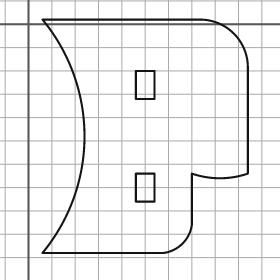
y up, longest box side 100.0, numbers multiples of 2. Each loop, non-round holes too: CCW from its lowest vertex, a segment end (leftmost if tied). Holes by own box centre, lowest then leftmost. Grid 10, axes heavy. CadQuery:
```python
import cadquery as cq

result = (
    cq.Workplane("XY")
    .moveTo(6.0, -98.0)
    .lineTo(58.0, -98.0)
    .threePointArc((66.0, -94.0), (70.0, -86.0))
    .lineTo(70.0, -64.0)
    .threePointArc((82.0, -66.0), (94.0, -64.0))
    .lineTo(94.0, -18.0)
    .threePointArc((88.0, -4.0), (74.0, 2.0))
    .lineTo(6.0, 2.0)
    .threePointArc((24.0, -48.0), (6.0, -98.0))
    .close()
    .moveTo(46.0, -76.0)
    .lineTo(54.0, -76.0)
    .lineTo(54.0, -64.0)
    .lineTo(46.0, -64.0)
    .close()
    .moveTo(46.0, -32.0)
    .lineTo(54.0, -32.0)
    .lineTo(54.0, -20.0)
    .lineTo(46.0, -20.0)
    .close()
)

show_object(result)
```